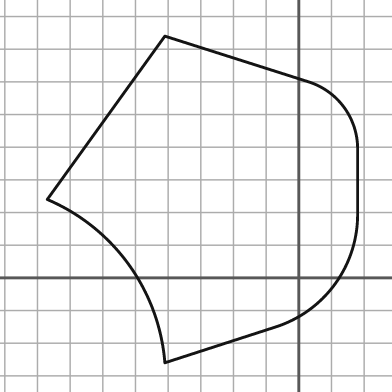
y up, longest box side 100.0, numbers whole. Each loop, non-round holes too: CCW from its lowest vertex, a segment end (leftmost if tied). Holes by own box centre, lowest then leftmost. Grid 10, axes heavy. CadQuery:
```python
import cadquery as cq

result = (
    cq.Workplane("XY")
    .moveTo(-41.0, -26.0)
    .lineTo(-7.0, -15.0)
    .threePointArc((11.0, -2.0), (18.0, 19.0))
    .lineTo(18.0, 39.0)
    .threePointArc((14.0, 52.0), (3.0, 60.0))
    .lineTo(-41.0, 74.0)
    .lineTo(-77.0, 24.0)
    .threePointArc((-52.0, 4.0), (-41.0, -26.0))
    .close()
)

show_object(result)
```